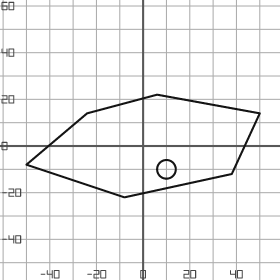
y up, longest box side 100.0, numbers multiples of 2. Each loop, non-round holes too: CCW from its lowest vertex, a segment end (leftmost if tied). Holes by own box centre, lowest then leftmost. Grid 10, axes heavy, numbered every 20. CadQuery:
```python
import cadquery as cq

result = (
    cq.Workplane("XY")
    .moveTo(-8.0, -22.0)
    .lineTo(38.0, -12.0)
    .lineTo(50.0, 14.0)
    .lineTo(6.0, 22.0)
    .lineTo(-24.0, 14.0)
    .lineTo(-50.0, -8.0)
    .close()
    .moveTo(10.0, -10.0)
    .circle(4.0)
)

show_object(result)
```